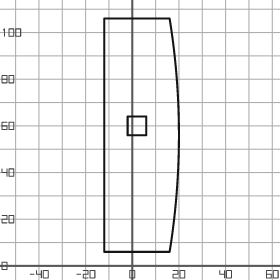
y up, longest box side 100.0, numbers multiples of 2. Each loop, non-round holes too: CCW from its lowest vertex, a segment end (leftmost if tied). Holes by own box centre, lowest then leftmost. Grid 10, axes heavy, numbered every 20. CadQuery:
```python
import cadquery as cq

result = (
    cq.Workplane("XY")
    .moveTo(-12.0, 6.0)
    .lineTo(16.0, 6.0)
    .threePointArc((20.0, 56.0), (16.0, 106.0))
    .lineTo(-12.0, 106.0)
    .close()
    .moveTo(-2.0, 56.0)
    .lineTo(6.0, 56.0)
    .lineTo(6.0, 64.0)
    .lineTo(-2.0, 64.0)
    .close()
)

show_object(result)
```